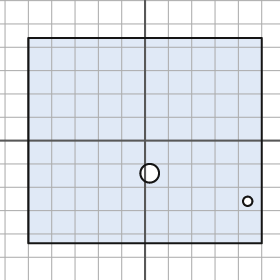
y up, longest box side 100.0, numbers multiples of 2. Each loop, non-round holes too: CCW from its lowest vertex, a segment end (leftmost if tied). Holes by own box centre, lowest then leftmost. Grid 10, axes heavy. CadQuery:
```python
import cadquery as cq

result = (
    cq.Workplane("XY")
    .moveTo(-50.0, -44.0)
    .lineTo(50.0, -44.0)
    .lineTo(50.0, 44.0)
    .lineTo(-50.0, 44.0)
    .close()
    .moveTo(44.0, -26.0)
    .circle(2.0)
    .moveTo(2.0, -14.0)
    .circle(4.0)
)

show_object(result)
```